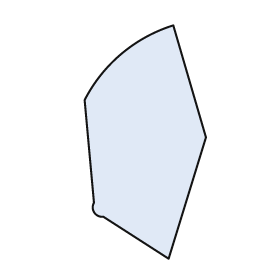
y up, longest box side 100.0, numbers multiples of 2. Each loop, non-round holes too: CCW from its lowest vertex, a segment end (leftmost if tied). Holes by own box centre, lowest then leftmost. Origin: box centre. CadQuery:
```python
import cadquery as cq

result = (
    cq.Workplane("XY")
    .moveTo(10.0, -50.0)
    .lineTo(26.0, 2.0)
    .lineTo(12.0, 50.0)
    .threePointArc((-10.0, 38.0), (-26.0, 18.0))
    .lineTo(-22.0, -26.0)
    .threePointArc((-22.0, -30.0), (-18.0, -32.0))
    .close()
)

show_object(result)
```